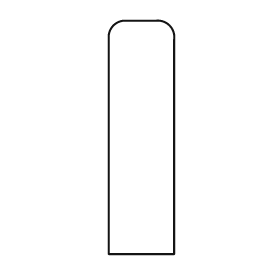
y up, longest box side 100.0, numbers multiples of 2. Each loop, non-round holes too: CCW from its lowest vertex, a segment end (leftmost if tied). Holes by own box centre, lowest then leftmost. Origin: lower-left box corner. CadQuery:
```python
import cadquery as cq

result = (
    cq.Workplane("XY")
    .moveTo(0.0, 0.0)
    .lineTo(28.0, 0.0)
    .lineTo(28.0, 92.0)
    .threePointArc((26.0, 98.0), (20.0, 100.0))
    .lineTo(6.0, 100.0)
    .threePointArc((2.0, 98.0), (0.0, 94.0))
    .close()
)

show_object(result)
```